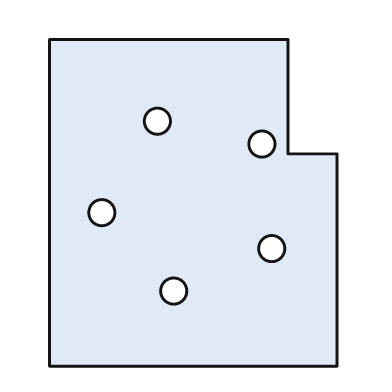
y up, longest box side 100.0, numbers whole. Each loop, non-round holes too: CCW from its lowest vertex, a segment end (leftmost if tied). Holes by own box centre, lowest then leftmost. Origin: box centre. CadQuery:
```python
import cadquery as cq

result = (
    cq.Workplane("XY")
    .moveTo(-44.0, -50.0)
    .lineTo(44.0, -50.0)
    .lineTo(44.0, 15.0)
    .lineTo(29.0, 15.0)
    .lineTo(29.0, 50.0)
    .lineTo(-44.0, 50.0)
    .close()
    .moveTo(-6.0, -27.0)
    .circle(4.0)
    .moveTo(24.0, -14.0)
    .circle(4.0)
    .moveTo(-28.0, -3.0)
    .circle(4.0)
    .moveTo(21.0, 18.0)
    .circle(4.0)
    .moveTo(-11.0, 25.0)
    .circle(4.0)
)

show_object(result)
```